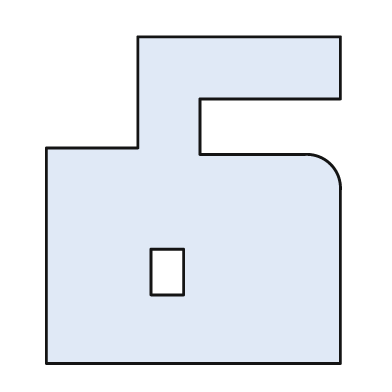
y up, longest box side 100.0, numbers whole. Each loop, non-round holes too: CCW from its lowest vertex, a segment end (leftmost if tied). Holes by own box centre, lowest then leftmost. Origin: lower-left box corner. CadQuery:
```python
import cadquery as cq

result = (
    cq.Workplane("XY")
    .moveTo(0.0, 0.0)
    .lineTo(90.0, 0.0)
    .lineTo(90.0, 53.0)
    .threePointArc((87.0, 61.0), (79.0, 64.0))
    .lineTo(47.0, 64.0)
    .lineTo(47.0, 81.0)
    .lineTo(90.0, 81.0)
    .lineTo(90.0, 100.0)
    .lineTo(28.0, 100.0)
    .lineTo(28.0, 66.0)
    .lineTo(0.0, 66.0)
    .close()
    .moveTo(32.0, 21.0)
    .lineTo(42.0, 21.0)
    .lineTo(42.0, 35.0)
    .lineTo(32.0, 35.0)
    .close()
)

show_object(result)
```